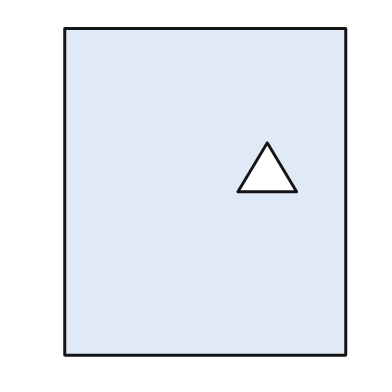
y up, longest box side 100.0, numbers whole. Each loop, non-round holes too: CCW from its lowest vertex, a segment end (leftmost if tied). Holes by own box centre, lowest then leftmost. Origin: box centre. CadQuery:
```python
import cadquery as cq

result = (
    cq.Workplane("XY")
    .moveTo(-43.0, -50.0)
    .lineTo(43.0, -50.0)
    .lineTo(43.0, 50.0)
    .lineTo(-43.0, 50.0)
    .close()
    .moveTo(10.0, 0.0)
    .lineTo(28.0, 0.0)
    .lineTo(19.0, 15.0)
    .close()
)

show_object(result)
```